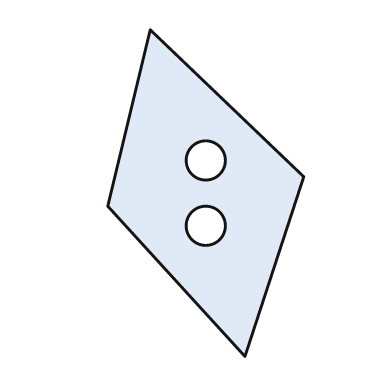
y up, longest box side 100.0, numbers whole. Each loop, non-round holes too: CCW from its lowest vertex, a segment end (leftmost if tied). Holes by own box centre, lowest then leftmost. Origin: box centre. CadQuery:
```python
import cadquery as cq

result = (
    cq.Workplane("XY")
    .moveTo(12.0, -50.0)
    .lineTo(30.0, 5.0)
    .lineTo(-17.0, 50.0)
    .lineTo(-30.0, -4.0)
    .close()
    .moveTo(0.0, -10.0)
    .circle(6.0)
    .moveTo(0.0, 10.0)
    .circle(6.0)
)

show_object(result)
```